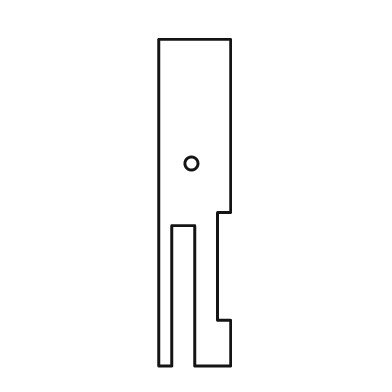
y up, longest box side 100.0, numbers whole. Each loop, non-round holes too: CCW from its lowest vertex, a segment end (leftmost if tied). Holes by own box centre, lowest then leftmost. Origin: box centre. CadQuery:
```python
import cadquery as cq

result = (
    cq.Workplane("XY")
    .moveTo(-11.0, -50.0)
    .lineTo(-7.0, -50.0)
    .lineTo(-7.0, -7.0)
    .lineTo(0.0, -7.0)
    .lineTo(0.0, -50.0)
    .lineTo(11.0, -50.0)
    .lineTo(11.0, -36.0)
    .lineTo(7.0, -36.0)
    .lineTo(7.0, -3.0)
    .lineTo(11.0, -3.0)
    .lineTo(11.0, 50.0)
    .lineTo(-11.0, 50.0)
    .close()
    .moveTo(-1.0, 12.0)
    .circle(2.0)
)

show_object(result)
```